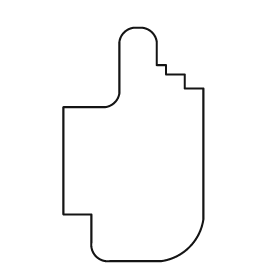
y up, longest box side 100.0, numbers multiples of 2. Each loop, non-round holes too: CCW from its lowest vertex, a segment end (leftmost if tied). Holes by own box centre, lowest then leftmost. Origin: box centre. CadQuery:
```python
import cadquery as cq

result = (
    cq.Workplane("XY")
    .moveTo(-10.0, -50.0)
    .lineTo(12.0, -50.0)
    .threePointArc((24.0, -44.0), (30.0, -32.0))
    .lineTo(30.0, 24.0)
    .lineTo(22.0, 24.0)
    .lineTo(22.0, 30.0)
    .lineTo(14.0, 30.0)
    .lineTo(14.0, 34.0)
    .lineTo(10.0, 34.0)
    .lineTo(10.0, 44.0)
    .threePointArc((8.0, 48.0), (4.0, 50.0))
    .lineTo(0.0, 50.0)
    .threePointArc((-4.0, 48.0), (-6.0, 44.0))
    .lineTo(-6.0, 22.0)
    .threePointArc((-8.0, 18.0), (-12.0, 16.0))
    .lineTo(-30.0, 16.0)
    .lineTo(-30.0, -30.0)
    .lineTo(-18.0, -30.0)
    .lineTo(-18.0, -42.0)
    .threePointArc((-16.0, -48.0), (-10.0, -50.0))
    .close()
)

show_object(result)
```